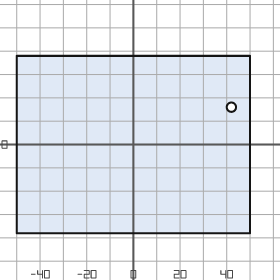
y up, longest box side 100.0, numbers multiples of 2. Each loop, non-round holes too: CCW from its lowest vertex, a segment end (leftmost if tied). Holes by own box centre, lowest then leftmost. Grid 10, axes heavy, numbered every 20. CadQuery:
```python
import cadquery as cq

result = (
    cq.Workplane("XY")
    .moveTo(-50.0, -38.0)
    .lineTo(50.0, -38.0)
    .lineTo(50.0, 38.0)
    .lineTo(-50.0, 38.0)
    .close()
    .moveTo(42.0, 16.0)
    .circle(2.0)
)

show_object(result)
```